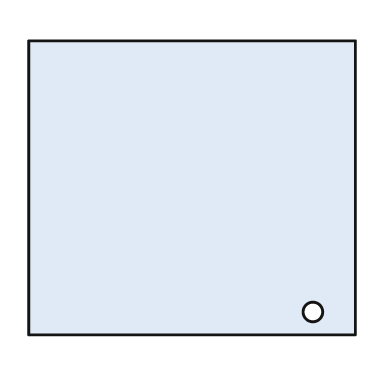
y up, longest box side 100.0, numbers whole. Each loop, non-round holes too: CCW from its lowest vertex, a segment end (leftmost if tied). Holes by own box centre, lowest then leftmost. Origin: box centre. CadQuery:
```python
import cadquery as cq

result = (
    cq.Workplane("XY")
    .moveTo(-50.0, -45.0)
    .lineTo(50.0, -45.0)
    .lineTo(50.0, 45.0)
    .lineTo(-50.0, 45.0)
    .close()
    .moveTo(37.0, -38.0)
    .circle(3.0)
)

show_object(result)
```